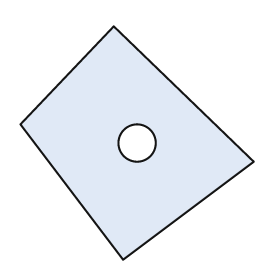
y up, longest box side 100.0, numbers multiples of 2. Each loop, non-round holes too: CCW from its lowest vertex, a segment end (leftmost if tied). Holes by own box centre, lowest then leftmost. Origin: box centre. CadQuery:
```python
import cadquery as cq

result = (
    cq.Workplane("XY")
    .moveTo(-6.0, -50.0)
    .lineTo(50.0, -8.0)
    .lineTo(-10.0, 50.0)
    .lineTo(-50.0, 8.0)
    .close()
    .moveTo(0.0, 0.0)
    .circle(8.0)
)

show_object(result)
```